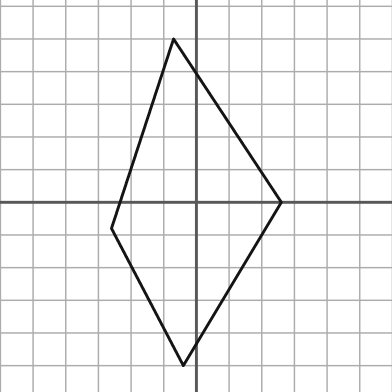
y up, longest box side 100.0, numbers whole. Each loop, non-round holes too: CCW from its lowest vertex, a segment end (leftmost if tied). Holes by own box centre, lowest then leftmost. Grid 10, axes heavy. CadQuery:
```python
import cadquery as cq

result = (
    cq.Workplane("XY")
    .moveTo(-4.0, -50.0)
    .lineTo(26.0, 0.0)
    .lineTo(-7.0, 50.0)
    .lineTo(-26.0, -8.0)
    .close()
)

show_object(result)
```